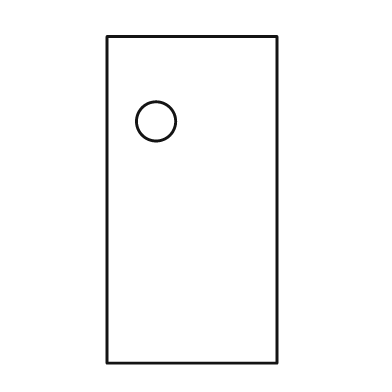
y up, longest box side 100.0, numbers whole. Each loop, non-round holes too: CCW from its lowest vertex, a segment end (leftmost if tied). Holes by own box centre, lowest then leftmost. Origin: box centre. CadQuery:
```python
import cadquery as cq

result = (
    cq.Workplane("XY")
    .moveTo(-26.0, -50.0)
    .lineTo(26.0, -50.0)
    .lineTo(26.0, 50.0)
    .lineTo(-26.0, 50.0)
    .close()
    .moveTo(-11.0, 24.0)
    .circle(6.0)
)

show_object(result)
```